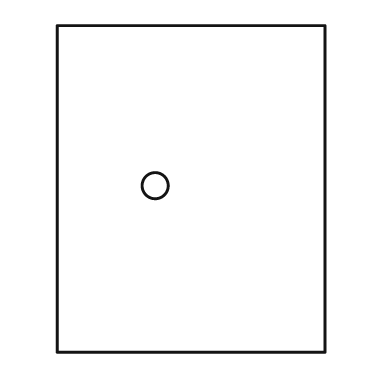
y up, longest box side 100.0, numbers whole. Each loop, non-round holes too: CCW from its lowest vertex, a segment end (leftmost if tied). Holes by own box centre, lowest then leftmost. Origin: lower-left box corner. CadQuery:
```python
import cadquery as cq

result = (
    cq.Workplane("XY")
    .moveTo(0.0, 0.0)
    .lineTo(82.0, 0.0)
    .lineTo(82.0, 100.0)
    .lineTo(0.0, 100.0)
    .close()
    .moveTo(30.0, 51.0)
    .circle(4.0)
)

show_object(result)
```